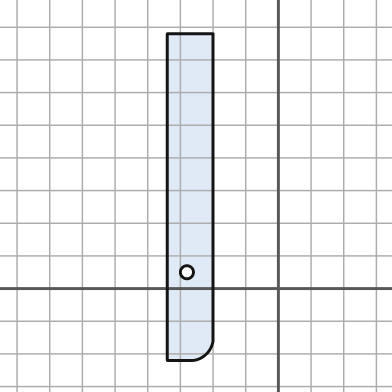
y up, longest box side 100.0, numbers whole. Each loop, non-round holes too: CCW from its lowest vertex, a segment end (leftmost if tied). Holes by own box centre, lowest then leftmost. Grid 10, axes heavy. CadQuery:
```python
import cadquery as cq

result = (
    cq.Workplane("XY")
    .moveTo(-34.0, -22.0)
    .lineTo(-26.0, -22.0)
    .threePointArc((-22.0, -20.0), (-20.0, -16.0))
    .lineTo(-20.0, 78.0)
    .lineTo(-34.0, 78.0)
    .close()
    .moveTo(-28.0, 5.0)
    .circle(2.0)
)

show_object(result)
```